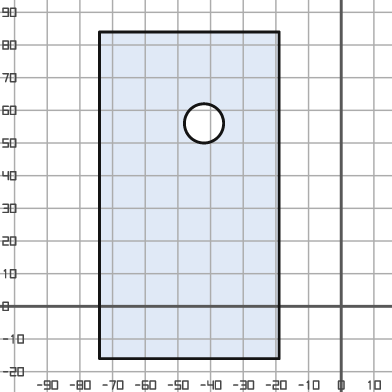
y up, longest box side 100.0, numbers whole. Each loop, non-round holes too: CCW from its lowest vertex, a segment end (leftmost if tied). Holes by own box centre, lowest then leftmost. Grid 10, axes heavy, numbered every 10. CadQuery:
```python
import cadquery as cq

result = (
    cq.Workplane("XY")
    .moveTo(-74.0, -16.0)
    .lineTo(-19.0, -16.0)
    .lineTo(-19.0, 84.0)
    .lineTo(-74.0, 84.0)
    .close()
    .moveTo(-42.0, 56.0)
    .circle(6.0)
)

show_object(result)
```